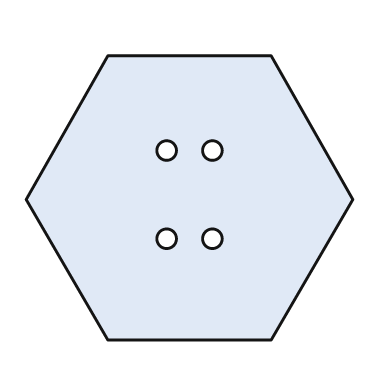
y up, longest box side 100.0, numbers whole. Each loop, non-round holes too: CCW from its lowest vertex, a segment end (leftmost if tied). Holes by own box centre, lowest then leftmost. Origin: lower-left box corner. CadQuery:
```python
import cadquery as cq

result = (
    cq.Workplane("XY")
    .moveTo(25.0, 0.0)
    .lineTo(75.0, 0.0)
    .lineTo(100.0, 43.0)
    .lineTo(75.0, 87.0)
    .lineTo(25.0, 87.0)
    .lineTo(0.0, 43.0)
    .close()
    .moveTo(43.0, 31.0)
    .circle(3.0)
    .moveTo(57.0, 31.0)
    .circle(3.0)
    .moveTo(43.0, 58.0)
    .circle(3.0)
    .moveTo(57.0, 58.0)
    .circle(3.0)
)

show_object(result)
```